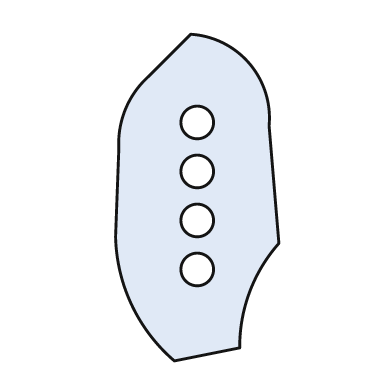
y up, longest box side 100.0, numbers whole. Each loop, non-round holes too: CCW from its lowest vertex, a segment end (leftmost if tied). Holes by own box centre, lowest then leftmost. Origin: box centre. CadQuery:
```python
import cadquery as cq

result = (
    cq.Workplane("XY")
    .moveTo(-7.0, -50.0)
    .lineTo(13.0, -46.0)
    .threePointArc((16.0, -29.0), (25.0, -14.0))
    .lineTo(22.0, 22.0)
    .threePointArc((16.0, 41.0), (-2.0, 50.0))
    .lineTo(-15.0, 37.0)
    .threePointArc((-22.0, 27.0), (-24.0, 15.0))
    .lineTo(-25.0, -12.0)
    .threePointArc((-20.0, -33.0), (-7.0, -50.0))
    .close()
    .moveTo(0.0, -22.0)
    .circle(5.0)
    .moveTo(0.0, -7.0)
    .circle(5.0)
    .moveTo(0.0, 8.0)
    .circle(5.0)
    .moveTo(0.0, 23.0)
    .circle(5.0)
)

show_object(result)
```